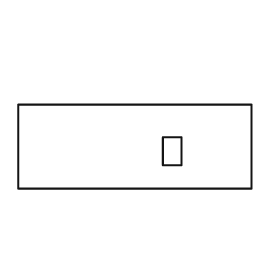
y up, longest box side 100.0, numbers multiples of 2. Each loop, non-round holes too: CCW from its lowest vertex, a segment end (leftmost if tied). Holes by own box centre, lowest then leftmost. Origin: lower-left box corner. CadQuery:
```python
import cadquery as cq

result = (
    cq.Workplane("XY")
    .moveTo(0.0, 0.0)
    .lineTo(100.0, 0.0)
    .lineTo(100.0, 36.0)
    .lineTo(0.0, 36.0)
    .close()
    .moveTo(62.0, 10.0)
    .lineTo(70.0, 10.0)
    .lineTo(70.0, 22.0)
    .lineTo(62.0, 22.0)
    .close()
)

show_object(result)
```